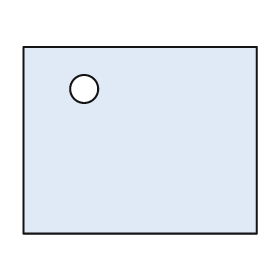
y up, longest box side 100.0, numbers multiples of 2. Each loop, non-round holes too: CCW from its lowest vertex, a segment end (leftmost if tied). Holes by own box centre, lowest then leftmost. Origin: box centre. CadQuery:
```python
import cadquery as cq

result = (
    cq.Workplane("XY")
    .moveTo(-50.0, -40.0)
    .lineTo(50.0, -40.0)
    .lineTo(50.0, 40.0)
    .lineTo(-50.0, 40.0)
    .close()
    .moveTo(-24.0, 22.0)
    .circle(6.0)
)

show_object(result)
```